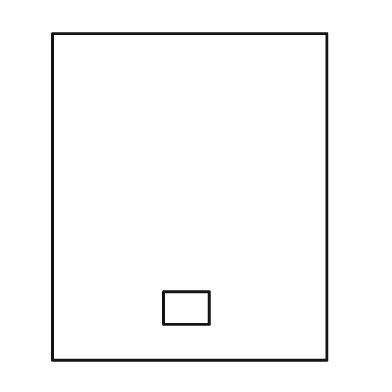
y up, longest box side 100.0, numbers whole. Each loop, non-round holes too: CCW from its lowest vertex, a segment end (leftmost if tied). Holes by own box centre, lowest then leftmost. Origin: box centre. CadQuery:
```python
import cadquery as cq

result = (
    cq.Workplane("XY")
    .moveTo(-42.0, -50.0)
    .lineTo(42.0, -50.0)
    .lineTo(42.0, 50.0)
    .lineTo(-42.0, 50.0)
    .close()
    .moveTo(-8.0, -39.0)
    .lineTo(6.0, -39.0)
    .lineTo(6.0, -29.0)
    .lineTo(-8.0, -29.0)
    .close()
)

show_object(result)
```